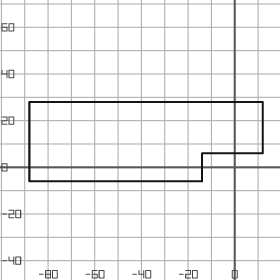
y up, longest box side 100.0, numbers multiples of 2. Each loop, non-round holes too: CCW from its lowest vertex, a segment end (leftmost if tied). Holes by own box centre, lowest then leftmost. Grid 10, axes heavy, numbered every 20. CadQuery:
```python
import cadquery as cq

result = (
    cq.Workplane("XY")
    .moveTo(-88.0, -6.0)
    .lineTo(-14.0, -6.0)
    .lineTo(-14.0, 6.0)
    .lineTo(12.0, 6.0)
    .lineTo(12.0, 28.0)
    .lineTo(-88.0, 28.0)
    .close()
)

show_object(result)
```